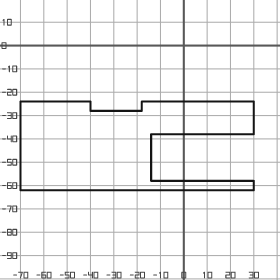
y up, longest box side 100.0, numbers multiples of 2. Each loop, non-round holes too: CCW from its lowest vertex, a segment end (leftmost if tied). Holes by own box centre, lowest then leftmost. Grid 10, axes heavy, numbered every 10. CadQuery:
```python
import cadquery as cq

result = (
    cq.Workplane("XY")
    .moveTo(-70.0, -62.0)
    .lineTo(30.0, -62.0)
    .lineTo(30.0, -58.0)
    .lineTo(-14.0, -58.0)
    .lineTo(-14.0, -38.0)
    .lineTo(30.0, -38.0)
    .lineTo(30.0, -24.0)
    .lineTo(-18.0, -24.0)
    .lineTo(-18.0, -28.0)
    .lineTo(-40.0, -28.0)
    .lineTo(-40.0, -24.0)
    .lineTo(-70.0, -24.0)
    .close()
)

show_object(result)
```